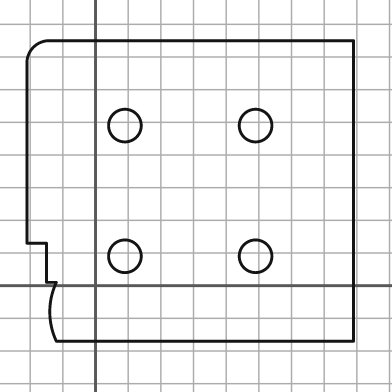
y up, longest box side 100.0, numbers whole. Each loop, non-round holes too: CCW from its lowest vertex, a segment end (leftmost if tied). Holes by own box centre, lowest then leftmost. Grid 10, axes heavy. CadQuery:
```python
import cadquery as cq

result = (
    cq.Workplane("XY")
    .moveTo(-12.0, -17.0)
    .lineTo(79.0, -17.0)
    .lineTo(79.0, 75.0)
    .lineTo(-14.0, 75.0)
    .threePointArc((-19.0, 73.0), (-21.0, 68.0))
    .lineTo(-21.0, 13.0)
    .lineTo(-15.0, 13.0)
    .lineTo(-15.0, 1.0)
    .lineTo(-12.0, 1.0)
    .threePointArc((-14.0, -8.0), (-12.0, -17.0))
    .close()
    .moveTo(9.0, 9.0)
    .circle(5.0)
    .moveTo(49.0, 9.0)
    .circle(5.0)
    .moveTo(9.0, 49.0)
    .circle(5.0)
    .moveTo(49.0, 49.0)
    .circle(5.0)
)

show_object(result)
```